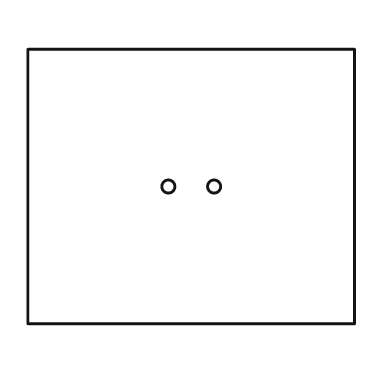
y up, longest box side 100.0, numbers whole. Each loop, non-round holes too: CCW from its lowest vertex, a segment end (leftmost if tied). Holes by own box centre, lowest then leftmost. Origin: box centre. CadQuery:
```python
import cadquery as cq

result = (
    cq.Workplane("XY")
    .moveTo(-50.0, -42.0)
    .lineTo(50.0, -42.0)
    .lineTo(50.0, 42.0)
    .lineTo(-50.0, 42.0)
    .close()
    .moveTo(-7.0, 0.0)
    .circle(2.0)
    .moveTo(7.0, 0.0)
    .circle(2.0)
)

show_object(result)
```